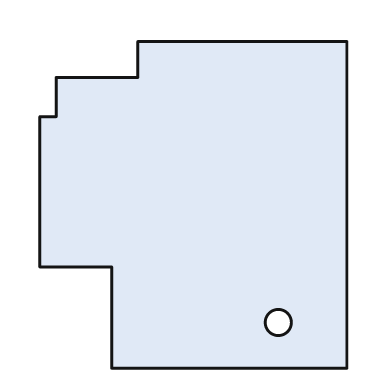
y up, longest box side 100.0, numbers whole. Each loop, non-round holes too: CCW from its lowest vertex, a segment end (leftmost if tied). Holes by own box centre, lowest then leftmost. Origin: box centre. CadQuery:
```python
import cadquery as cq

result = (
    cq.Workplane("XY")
    .moveTo(-25.0, -50.0)
    .lineTo(47.0, -50.0)
    .lineTo(47.0, 50.0)
    .lineTo(-17.0, 50.0)
    .lineTo(-17.0, 39.0)
    .lineTo(-42.0, 39.0)
    .lineTo(-42.0, 27.0)
    .lineTo(-47.0, 27.0)
    .lineTo(-47.0, -19.0)
    .lineTo(-25.0, -19.0)
    .close()
    .moveTo(26.0, -36.0)
    .circle(4.0)
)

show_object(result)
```